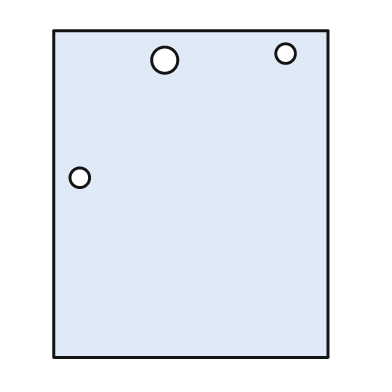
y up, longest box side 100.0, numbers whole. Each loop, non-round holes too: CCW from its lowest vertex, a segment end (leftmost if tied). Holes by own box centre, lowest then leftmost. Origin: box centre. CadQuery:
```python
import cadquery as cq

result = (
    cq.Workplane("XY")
    .moveTo(-42.0, -50.0)
    .lineTo(42.0, -50.0)
    .lineTo(42.0, 50.0)
    .lineTo(-42.0, 50.0)
    .close()
    .moveTo(-34.0, 5.0)
    .circle(3.0)
    .moveTo(-8.0, 41.0)
    .circle(4.0)
    .moveTo(29.0, 43.0)
    .circle(3.0)
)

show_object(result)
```